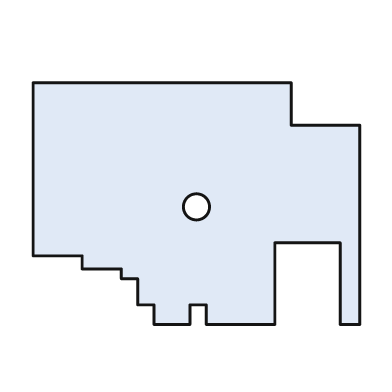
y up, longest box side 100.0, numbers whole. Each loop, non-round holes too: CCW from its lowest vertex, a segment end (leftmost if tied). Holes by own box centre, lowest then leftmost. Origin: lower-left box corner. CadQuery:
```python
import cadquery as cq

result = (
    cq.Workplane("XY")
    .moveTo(37.0, 0.0)
    .lineTo(48.0, 0.0)
    .lineTo(48.0, 6.0)
    .lineTo(53.0, 6.0)
    .lineTo(53.0, 0.0)
    .lineTo(74.0, 0.0)
    .lineTo(74.0, 25.0)
    .lineTo(94.0, 25.0)
    .lineTo(94.0, 0.0)
    .lineTo(100.0, 0.0)
    .lineTo(100.0, 61.0)
    .lineTo(79.0, 61.0)
    .lineTo(79.0, 74.0)
    .lineTo(0.0, 74.0)
    .lineTo(0.0, 21.0)
    .lineTo(15.0, 21.0)
    .lineTo(15.0, 17.0)
    .lineTo(27.0, 17.0)
    .lineTo(27.0, 14.0)
    .lineTo(32.0, 14.0)
    .lineTo(32.0, 6.0)
    .lineTo(37.0, 6.0)
    .close()
    .moveTo(50.0, 36.0)
    .circle(4.0)
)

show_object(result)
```